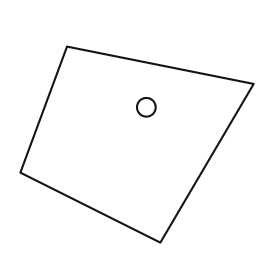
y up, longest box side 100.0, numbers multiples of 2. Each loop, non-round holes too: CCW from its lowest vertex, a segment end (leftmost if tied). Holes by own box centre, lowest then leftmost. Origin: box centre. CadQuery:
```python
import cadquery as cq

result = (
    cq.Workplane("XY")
    .moveTo(10.0, -42.0)
    .lineTo(50.0, 26.0)
    .lineTo(-30.0, 42.0)
    .lineTo(-50.0, -12.0)
    .close()
    .moveTo(4.0, 16.0)
    .circle(4.0)
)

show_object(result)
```